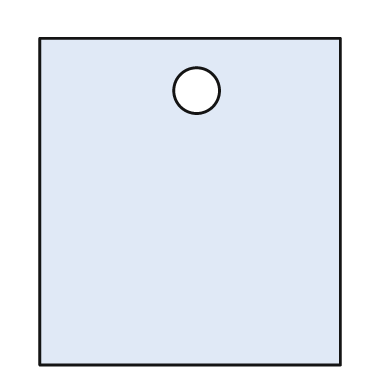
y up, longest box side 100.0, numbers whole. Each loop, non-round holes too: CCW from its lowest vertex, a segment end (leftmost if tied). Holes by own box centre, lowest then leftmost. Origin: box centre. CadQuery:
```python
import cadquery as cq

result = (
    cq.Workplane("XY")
    .moveTo(-46.0, -50.0)
    .lineTo(46.0, -50.0)
    .lineTo(46.0, 50.0)
    .lineTo(-46.0, 50.0)
    .close()
    .moveTo(2.0, 34.0)
    .circle(7.0)
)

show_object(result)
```